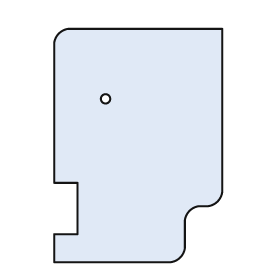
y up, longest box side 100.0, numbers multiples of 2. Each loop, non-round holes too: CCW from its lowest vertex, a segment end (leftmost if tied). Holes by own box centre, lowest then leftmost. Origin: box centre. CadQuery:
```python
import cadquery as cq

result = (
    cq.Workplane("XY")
    .moveTo(-36.0, -50.0)
    .lineTo(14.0, -50.0)
    .threePointArc((18.0, -48.0), (20.0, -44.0))
    .lineTo(20.0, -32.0)
    .threePointArc((22.0, -28.0), (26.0, -26.0))
    .lineTo(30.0, -26.0)
    .threePointArc((34.0, -24.0), (36.0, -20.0))
    .lineTo(36.0, 50.0)
    .lineTo(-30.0, 50.0)
    .threePointArc((-34.0, 48.0), (-36.0, 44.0))
    .lineTo(-36.0, -16.0)
    .lineTo(-26.0, -16.0)
    .lineTo(-26.0, -38.0)
    .lineTo(-36.0, -38.0)
    .close()
    .moveTo(-14.0, 20.0)
    .circle(2.0)
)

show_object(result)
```